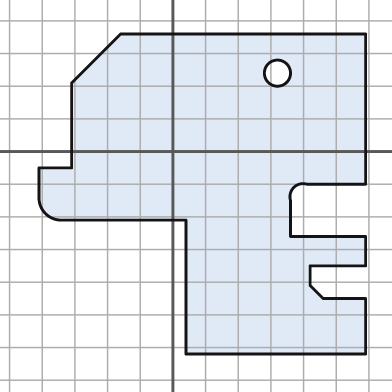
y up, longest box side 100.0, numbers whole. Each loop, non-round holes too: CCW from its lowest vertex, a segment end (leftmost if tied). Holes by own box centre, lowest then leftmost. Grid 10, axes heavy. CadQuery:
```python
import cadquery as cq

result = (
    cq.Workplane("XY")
    .moveTo(4.0, -62.0)
    .lineTo(59.0, -62.0)
    .lineTo(59.0, -45.0)
    .lineTo(46.0, -45.0)
    .lineTo(42.0, -41.0)
    .lineTo(42.0, -35.0)
    .lineTo(59.0, -35.0)
    .lineTo(59.0, -26.0)
    .lineTo(36.0, -26.0)
    .lineTo(36.0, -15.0)
    .threePointArc((37.0, -11.0), (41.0, -10.0))
    .lineTo(59.0, -10.0)
    .lineTo(59.0, 36.0)
    .lineTo(-16.0, 36.0)
    .lineTo(-31.0, 21.0)
    .lineTo(-31.0, -5.0)
    .lineTo(-41.0, -5.0)
    .lineTo(-41.0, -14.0)
    .threePointArc((-39.0, -19.0), (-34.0, -21.0))
    .lineTo(4.0, -21.0)
    .close()
    .moveTo(32.0, 24.0)
    .circle(4.0)
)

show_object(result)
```